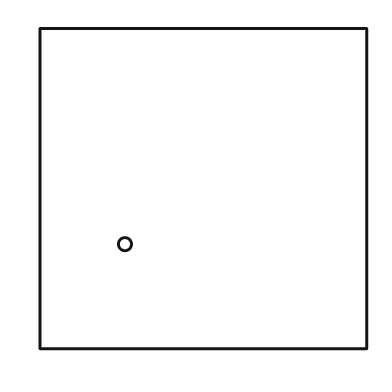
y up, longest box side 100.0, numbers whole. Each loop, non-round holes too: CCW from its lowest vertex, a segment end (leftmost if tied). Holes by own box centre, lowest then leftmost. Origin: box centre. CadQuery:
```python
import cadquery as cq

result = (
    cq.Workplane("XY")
    .moveTo(-50.0, -49.0)
    .lineTo(50.0, -49.0)
    .lineTo(50.0, 49.0)
    .lineTo(-50.0, 49.0)
    .close()
    .moveTo(-24.0, -17.0)
    .circle(2.0)
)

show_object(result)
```